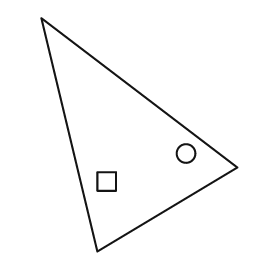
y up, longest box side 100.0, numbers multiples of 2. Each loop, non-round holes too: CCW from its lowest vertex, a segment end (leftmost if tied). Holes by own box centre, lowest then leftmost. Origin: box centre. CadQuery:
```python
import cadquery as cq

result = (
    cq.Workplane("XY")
    .moveTo(-18.0, -50.0)
    .lineTo(42.0, -14.0)
    .lineTo(-42.0, 50.0)
    .close()
    .moveTo(-18.0, -24.0)
    .lineTo(-10.0, -24.0)
    .lineTo(-10.0, -16.0)
    .lineTo(-18.0, -16.0)
    .close()
    .moveTo(20.0, -8.0)
    .circle(4.0)
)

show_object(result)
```